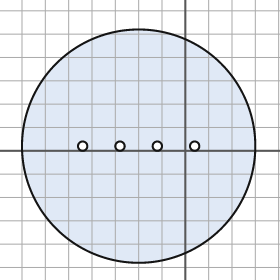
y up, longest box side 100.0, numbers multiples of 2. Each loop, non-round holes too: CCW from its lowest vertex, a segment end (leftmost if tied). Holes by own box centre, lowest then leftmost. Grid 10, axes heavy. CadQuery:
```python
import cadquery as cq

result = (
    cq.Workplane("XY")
    .moveTo(-20.0, 2.0)
    .circle(50.0)
    .moveTo(-44.0, 2.0)
    .circle(2.0)
    .moveTo(-28.0, 2.0)
    .circle(2.0)
    .moveTo(-12.0, 2.0)
    .circle(2.0)
    .moveTo(4.0, 2.0)
    .circle(2.0)
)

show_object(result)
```